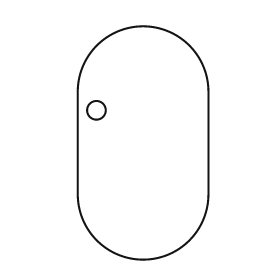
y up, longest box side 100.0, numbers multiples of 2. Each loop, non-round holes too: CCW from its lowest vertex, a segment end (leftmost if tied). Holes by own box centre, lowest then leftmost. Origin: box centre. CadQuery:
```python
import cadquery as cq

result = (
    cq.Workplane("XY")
    .moveTo(-28.0, -22.0)
    .threePointArc((0.0, -50.0), (28.0, -22.0))
    .lineTo(28.0, 22.0)
    .threePointArc((0.0, 50.0), (-28.0, 22.0))
    .close()
    .moveTo(-20.0, 14.0)
    .circle(4.0)
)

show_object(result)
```